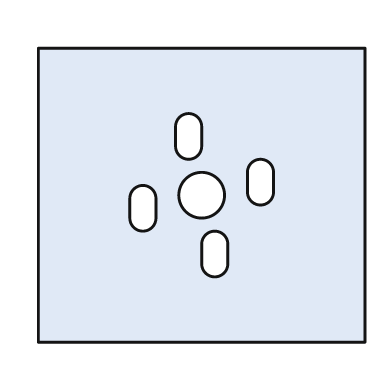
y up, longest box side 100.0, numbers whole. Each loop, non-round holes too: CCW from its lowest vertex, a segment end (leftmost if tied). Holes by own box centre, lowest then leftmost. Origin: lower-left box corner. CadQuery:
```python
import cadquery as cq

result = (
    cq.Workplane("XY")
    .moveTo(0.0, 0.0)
    .lineTo(100.0, 0.0)
    .lineTo(100.0, 90.0)
    .lineTo(0.0, 90.0)
    .close()
    .moveTo(50.0, 24.0)
    .threePointArc((54.0, 20.0), (58.0, 24.0))
    .lineTo(58.0, 30.0)
    .threePointArc((54.0, 34.0), (50.0, 30.0))
    .close()
    .moveTo(28.0, 38.0)
    .threePointArc((32.0, 34.0), (36.0, 38.0))
    .lineTo(36.0, 44.0)
    .threePointArc((32.0, 48.0), (28.0, 44.0))
    .close()
    .moveTo(50.0, 45.0)
    .circle(7.0)
    .moveTo(64.0, 46.0)
    .threePointArc((68.0, 42.0), (72.0, 46.0))
    .lineTo(72.0, 52.0)
    .threePointArc((68.0, 56.0), (64.0, 52.0))
    .close()
    .moveTo(42.0, 60.0)
    .threePointArc((46.0, 56.0), (50.0, 60.0))
    .lineTo(50.0, 66.0)
    .threePointArc((46.0, 70.0), (42.0, 66.0))
    .close()
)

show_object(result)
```